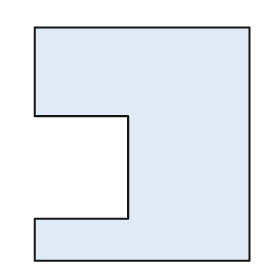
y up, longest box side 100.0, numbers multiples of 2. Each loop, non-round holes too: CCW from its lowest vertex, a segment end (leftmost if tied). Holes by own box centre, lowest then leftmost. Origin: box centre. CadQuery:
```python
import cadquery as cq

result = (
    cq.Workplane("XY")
    .moveTo(-46.0, -50.0)
    .lineTo(46.0, -50.0)
    .lineTo(46.0, 50.0)
    .lineTo(-46.0, 50.0)
    .lineTo(-46.0, 12.0)
    .lineTo(-6.0, 12.0)
    .lineTo(-6.0, -32.0)
    .lineTo(-46.0, -32.0)
    .close()
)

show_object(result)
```